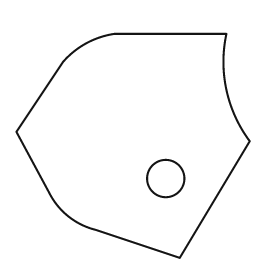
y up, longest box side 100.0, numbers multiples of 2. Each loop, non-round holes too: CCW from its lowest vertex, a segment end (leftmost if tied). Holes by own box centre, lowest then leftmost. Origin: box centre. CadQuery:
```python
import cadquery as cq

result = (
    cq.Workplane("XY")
    .moveTo(20.0, -48.0)
    .lineTo(50.0, 2.0)
    .threePointArc((40.0, 24.0), (40.0, 48.0))
    .lineTo(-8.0, 48.0)
    .threePointArc((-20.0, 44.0), (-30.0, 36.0))
    .lineTo(-50.0, 6.0)
    .lineTo(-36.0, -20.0)
    .threePointArc((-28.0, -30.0), (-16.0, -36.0))
    .close()
    .moveTo(14.0, -14.0)
    .circle(8.0)
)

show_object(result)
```